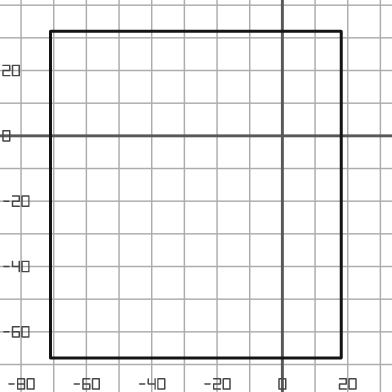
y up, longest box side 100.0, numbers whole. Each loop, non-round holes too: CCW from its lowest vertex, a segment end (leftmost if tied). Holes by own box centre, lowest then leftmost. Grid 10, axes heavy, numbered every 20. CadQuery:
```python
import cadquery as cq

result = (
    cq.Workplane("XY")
    .moveTo(-71.0, -68.0)
    .lineTo(18.0, -68.0)
    .lineTo(18.0, 32.0)
    .lineTo(-71.0, 32.0)
    .close()
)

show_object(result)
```